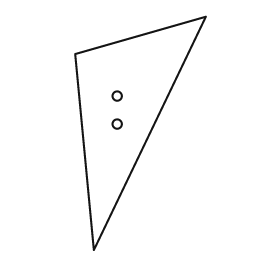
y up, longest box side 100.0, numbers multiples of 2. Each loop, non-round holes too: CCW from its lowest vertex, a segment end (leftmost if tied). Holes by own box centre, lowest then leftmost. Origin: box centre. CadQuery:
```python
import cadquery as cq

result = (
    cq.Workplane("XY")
    .moveTo(-20.0, -50.0)
    .lineTo(28.0, 50.0)
    .lineTo(-28.0, 34.0)
    .close()
    .moveTo(-10.0, 4.0)
    .circle(2.0)
    .moveTo(-10.0, 16.0)
    .circle(2.0)
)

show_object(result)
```